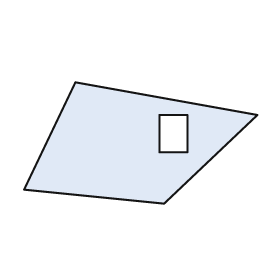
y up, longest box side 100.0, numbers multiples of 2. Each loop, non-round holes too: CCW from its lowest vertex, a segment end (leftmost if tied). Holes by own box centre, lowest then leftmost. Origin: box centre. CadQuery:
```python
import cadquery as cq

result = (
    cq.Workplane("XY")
    .moveTo(10.0, -26.0)
    .lineTo(50.0, 12.0)
    .lineTo(-28.0, 26.0)
    .lineTo(-50.0, -20.0)
    .close()
    .moveTo(8.0, -4.0)
    .lineTo(20.0, -4.0)
    .lineTo(20.0, 12.0)
    .lineTo(8.0, 12.0)
    .close()
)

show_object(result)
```